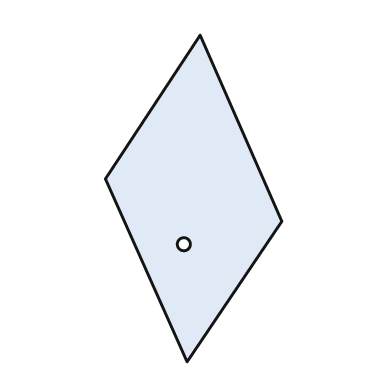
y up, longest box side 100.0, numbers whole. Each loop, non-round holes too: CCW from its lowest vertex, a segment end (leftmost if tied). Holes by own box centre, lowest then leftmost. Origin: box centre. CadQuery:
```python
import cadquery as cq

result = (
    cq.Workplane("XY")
    .moveTo(-2.0, -50.0)
    .lineTo(27.0, -7.0)
    .lineTo(2.0, 50.0)
    .lineTo(-27.0, 6.0)
    .close()
    .moveTo(-3.0, -14.0)
    .circle(2.0)
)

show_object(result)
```